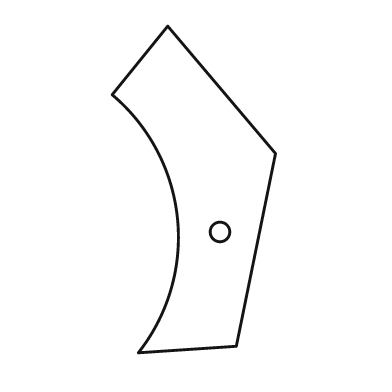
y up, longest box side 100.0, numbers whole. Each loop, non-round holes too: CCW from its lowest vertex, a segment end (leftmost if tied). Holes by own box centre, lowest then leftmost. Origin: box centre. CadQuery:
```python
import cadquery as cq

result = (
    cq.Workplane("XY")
    .moveTo(-17.0, -50.0)
    .lineTo(13.0, -48.0)
    .lineTo(25.0, 11.0)
    .lineTo(-8.0, 50.0)
    .lineTo(-25.0, 29.0)
    .threePointArc((-5.0, -9.0), (-17.0, -50.0))
    .close()
    .moveTo(8.0, -13.0)
    .circle(3.0)
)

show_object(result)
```